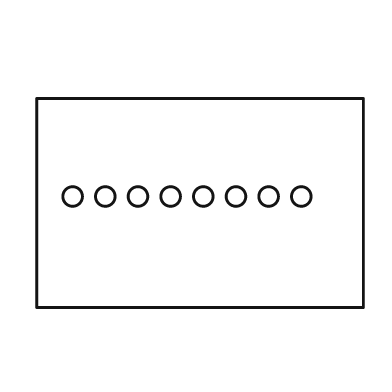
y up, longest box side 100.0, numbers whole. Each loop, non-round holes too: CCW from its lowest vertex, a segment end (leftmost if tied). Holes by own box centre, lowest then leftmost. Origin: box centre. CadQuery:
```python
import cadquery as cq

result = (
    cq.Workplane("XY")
    .moveTo(-50.0, -32.0)
    .lineTo(50.0, -32.0)
    .lineTo(50.0, 32.0)
    .lineTo(-50.0, 32.0)
    .close()
    .moveTo(-39.0, 2.0)
    .circle(3.0)
    .moveTo(-29.0, 2.0)
    .circle(3.0)
    .moveTo(-19.0, 2.0)
    .circle(3.0)
    .moveTo(-9.0, 2.0)
    .circle(3.0)
    .moveTo(1.0, 2.0)
    .circle(3.0)
    .moveTo(11.0, 2.0)
    .circle(3.0)
    .moveTo(21.0, 2.0)
    .circle(3.0)
    .moveTo(31.0, 2.0)
    .circle(3.0)
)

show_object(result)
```